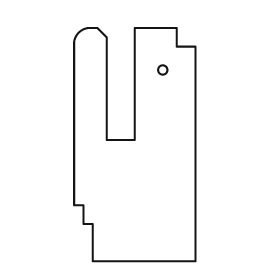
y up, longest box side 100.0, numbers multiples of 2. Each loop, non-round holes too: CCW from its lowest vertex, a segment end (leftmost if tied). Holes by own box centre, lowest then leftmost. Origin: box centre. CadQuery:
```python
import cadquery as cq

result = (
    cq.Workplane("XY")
    .moveTo(-18.0, -50.0)
    .lineTo(26.0, -50.0)
    .lineTo(26.0, 42.0)
    .lineTo(18.0, 42.0)
    .lineTo(18.0, 50.0)
    .lineTo(0.0, 50.0)
    .lineTo(0.0, 2.0)
    .lineTo(-12.0, 2.0)
    .lineTo(-12.0, 46.0)
    .lineTo(-16.0, 50.0)
    .lineTo(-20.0, 50.0)
    .threePointArc((-24.0, 48.0), (-26.0, 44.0))
    .lineTo(-26.0, -26.0)
    .lineTo(-22.0, -26.0)
    .lineTo(-22.0, -34.0)
    .lineTo(-18.0, -34.0)
    .close()
    .moveTo(12.0, 32.0)
    .circle(2.0)
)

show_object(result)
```